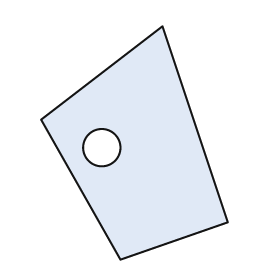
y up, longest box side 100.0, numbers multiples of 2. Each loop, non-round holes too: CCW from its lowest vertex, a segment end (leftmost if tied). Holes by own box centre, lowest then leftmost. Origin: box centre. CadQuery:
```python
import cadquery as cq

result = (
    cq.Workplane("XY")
    .moveTo(-6.0, -50.0)
    .lineTo(40.0, -34.0)
    .lineTo(12.0, 50.0)
    .lineTo(-40.0, 10.0)
    .close()
    .moveTo(-14.0, -2.0)
    .circle(8.0)
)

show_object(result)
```